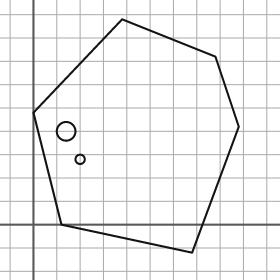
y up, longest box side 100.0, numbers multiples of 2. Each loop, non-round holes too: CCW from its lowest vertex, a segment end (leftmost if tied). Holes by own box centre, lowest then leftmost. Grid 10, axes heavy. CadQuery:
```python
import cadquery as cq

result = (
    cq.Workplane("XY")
    .moveTo(68.0, -12.0)
    .lineTo(88.0, 42.0)
    .lineTo(78.0, 72.0)
    .lineTo(38.0, 88.0)
    .lineTo(0.0, 48.0)
    .lineTo(12.0, 0.0)
    .close()
    .moveTo(20.0, 28.0)
    .circle(2.0)
    .moveTo(14.0, 40.0)
    .circle(4.0)
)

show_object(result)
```